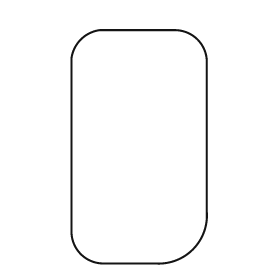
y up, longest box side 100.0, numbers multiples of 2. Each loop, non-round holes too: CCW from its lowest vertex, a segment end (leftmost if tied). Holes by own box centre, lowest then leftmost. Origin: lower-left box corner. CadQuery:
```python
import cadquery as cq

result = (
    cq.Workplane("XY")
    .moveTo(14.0, 0.0)
    .lineTo(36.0, 0.0)
    .threePointArc((52.0, 6.0), (58.0, 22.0))
    .lineTo(58.0, 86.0)
    .threePointArc((54.0, 96.0), (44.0, 100.0))
    .lineTo(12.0, 100.0)
    .threePointArc((4.0, 96.0), (0.0, 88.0))
    .lineTo(0.0, 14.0)
    .threePointArc((4.0, 4.0), (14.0, 0.0))
    .close()
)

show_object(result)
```